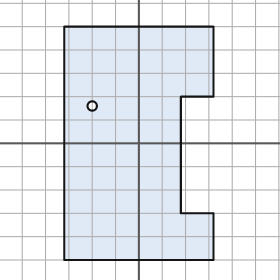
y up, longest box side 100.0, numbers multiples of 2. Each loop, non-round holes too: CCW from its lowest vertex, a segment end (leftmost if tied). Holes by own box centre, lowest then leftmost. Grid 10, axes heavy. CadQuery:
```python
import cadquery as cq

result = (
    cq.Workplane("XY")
    .moveTo(-32.0, -50.0)
    .lineTo(32.0, -50.0)
    .lineTo(32.0, -30.0)
    .lineTo(18.0, -30.0)
    .lineTo(18.0, 20.0)
    .lineTo(32.0, 20.0)
    .lineTo(32.0, 50.0)
    .lineTo(-32.0, 50.0)
    .close()
    .moveTo(-20.0, 16.0)
    .circle(2.0)
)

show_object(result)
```